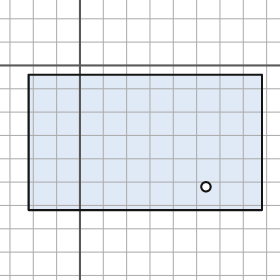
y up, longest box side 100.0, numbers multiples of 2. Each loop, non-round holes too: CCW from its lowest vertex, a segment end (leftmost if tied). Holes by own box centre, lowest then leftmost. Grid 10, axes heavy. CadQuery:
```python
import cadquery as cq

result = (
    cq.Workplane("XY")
    .moveTo(-22.0, -62.0)
    .lineTo(78.0, -62.0)
    .lineTo(78.0, -4.0)
    .lineTo(-22.0, -4.0)
    .close()
    .moveTo(54.0, -52.0)
    .circle(2.0)
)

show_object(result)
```